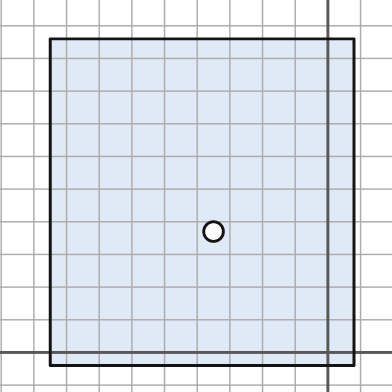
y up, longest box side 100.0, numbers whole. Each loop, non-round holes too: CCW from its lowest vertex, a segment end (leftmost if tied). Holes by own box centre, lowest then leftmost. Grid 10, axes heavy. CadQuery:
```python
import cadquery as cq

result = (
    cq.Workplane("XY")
    .moveTo(-85.0, -4.0)
    .lineTo(8.0, -4.0)
    .lineTo(8.0, 96.0)
    .lineTo(-85.0, 96.0)
    .close()
    .moveTo(-35.0, 37.0)
    .circle(3.0)
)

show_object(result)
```